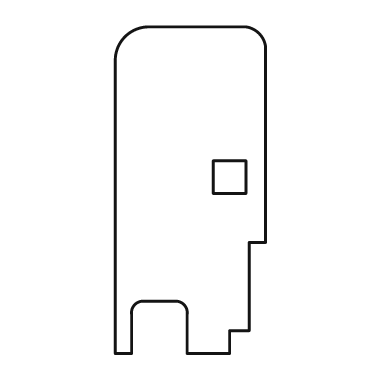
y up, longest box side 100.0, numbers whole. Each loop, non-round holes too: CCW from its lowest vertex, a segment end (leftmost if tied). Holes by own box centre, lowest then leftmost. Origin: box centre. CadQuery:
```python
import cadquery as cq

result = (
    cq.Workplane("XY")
    .moveTo(-23.0, -50.0)
    .lineTo(-18.0, -50.0)
    .lineTo(-18.0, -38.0)
    .threePointArc((-17.0, -35.0), (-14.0, -34.0))
    .lineTo(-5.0, -34.0)
    .threePointArc((-2.0, -35.0), (-1.0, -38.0))
    .lineTo(-1.0, -50.0)
    .lineTo(12.0, -50.0)
    .lineTo(12.0, -43.0)
    .lineTo(18.0, -43.0)
    .lineTo(18.0, -16.0)
    .lineTo(23.0, -16.0)
    .lineTo(23.0, 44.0)
    .threePointArc((21.0, 48.0), (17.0, 50.0))
    .lineTo(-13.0, 50.0)
    .threePointArc((-20.0, 47.0), (-23.0, 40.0))
    .close()
    .moveTo(7.0, -1.0)
    .lineTo(17.0, -1.0)
    .lineTo(17.0, 9.0)
    .lineTo(7.0, 9.0)
    .close()
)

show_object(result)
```